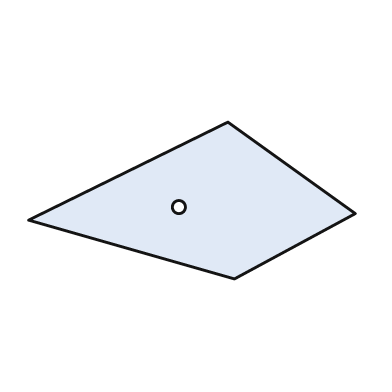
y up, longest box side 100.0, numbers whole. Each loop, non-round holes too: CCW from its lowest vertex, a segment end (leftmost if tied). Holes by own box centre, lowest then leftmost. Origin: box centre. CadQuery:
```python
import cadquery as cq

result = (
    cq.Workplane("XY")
    .moveTo(13.0, -24.0)
    .lineTo(50.0, -4.0)
    .lineTo(11.0, 24.0)
    .lineTo(-50.0, -6.0)
    .close()
    .moveTo(-4.0, -2.0)
    .circle(2.0)
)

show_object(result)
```